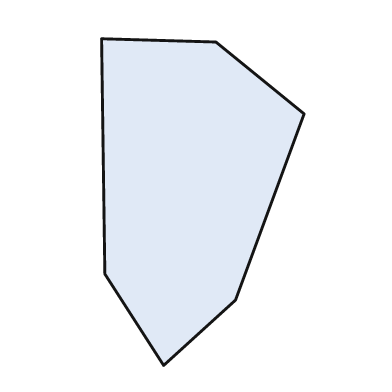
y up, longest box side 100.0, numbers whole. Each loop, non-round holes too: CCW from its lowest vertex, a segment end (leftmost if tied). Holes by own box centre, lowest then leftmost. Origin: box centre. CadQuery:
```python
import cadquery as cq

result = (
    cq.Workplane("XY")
    .moveTo(-12.0, -50.0)
    .lineTo(10.0, -30.0)
    .lineTo(31.0, 27.0)
    .lineTo(4.0, 49.0)
    .lineTo(-31.0, 50.0)
    .lineTo(-30.0, -22.0)
    .close()
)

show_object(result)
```